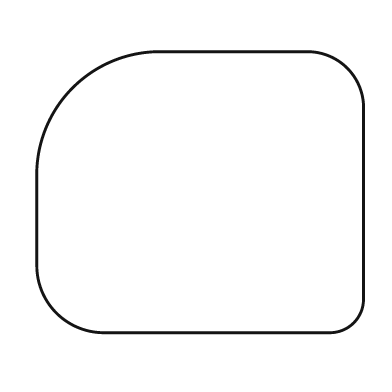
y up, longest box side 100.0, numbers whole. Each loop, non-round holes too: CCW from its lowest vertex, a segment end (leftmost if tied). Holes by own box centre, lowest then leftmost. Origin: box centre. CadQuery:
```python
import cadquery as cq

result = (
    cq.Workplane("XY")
    .moveTo(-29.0, -43.0)
    .lineTo(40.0, -43.0)
    .threePointArc((47.0, -40.0), (50.0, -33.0))
    .lineTo(50.0, 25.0)
    .threePointArc((45.0, 38.0), (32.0, 43.0))
    .lineTo(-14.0, 43.0)
    .threePointArc((-39.0, 32.0), (-50.0, 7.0))
    .lineTo(-50.0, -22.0)
    .threePointArc((-44.0, -37.0), (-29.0, -43.0))
    .close()
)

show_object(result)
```